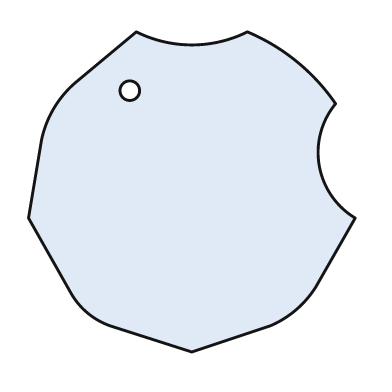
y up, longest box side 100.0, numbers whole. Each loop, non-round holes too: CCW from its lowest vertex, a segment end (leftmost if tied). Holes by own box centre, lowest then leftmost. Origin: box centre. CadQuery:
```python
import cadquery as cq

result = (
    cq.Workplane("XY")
    .moveTo(0.0, -49.0)
    .lineTo(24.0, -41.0)
    .threePointArc((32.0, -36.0), (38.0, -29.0))
    .lineTo(50.0, -8.0)
    .threePointArc((39.0, 8.0), (44.0, 27.0))
    .threePointArc((32.0, 40.0), (17.0, 49.0))
    .threePointArc((0.0, 45.0), (-17.0, 49.0))
    .lineTo(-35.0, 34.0)
    .threePointArc((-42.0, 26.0), (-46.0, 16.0))
    .lineTo(-50.0, -8.0)
    .lineTo(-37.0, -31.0)
    .threePointArc((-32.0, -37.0), (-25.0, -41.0))
    .close()
    .moveTo(-19.0, 31.0)
    .circle(3.0)
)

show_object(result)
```